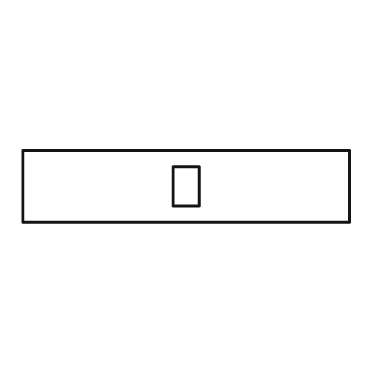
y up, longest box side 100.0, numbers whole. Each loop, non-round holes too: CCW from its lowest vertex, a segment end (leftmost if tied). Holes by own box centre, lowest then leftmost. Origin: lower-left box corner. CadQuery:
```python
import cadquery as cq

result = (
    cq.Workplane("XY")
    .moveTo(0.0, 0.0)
    .lineTo(100.0, 0.0)
    .lineTo(100.0, 22.0)
    .lineTo(0.0, 22.0)
    .close()
    .moveTo(46.0, 5.0)
    .lineTo(54.0, 5.0)
    .lineTo(54.0, 17.0)
    .lineTo(46.0, 17.0)
    .close()
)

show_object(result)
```